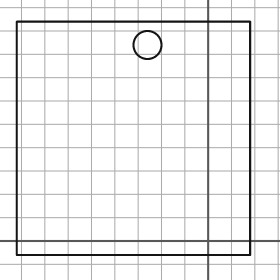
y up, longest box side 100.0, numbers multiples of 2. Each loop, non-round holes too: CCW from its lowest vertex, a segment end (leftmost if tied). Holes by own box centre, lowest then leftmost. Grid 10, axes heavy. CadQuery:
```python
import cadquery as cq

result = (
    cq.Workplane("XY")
    .moveTo(-82.0, -6.0)
    .lineTo(18.0, -6.0)
    .lineTo(18.0, 94.0)
    .lineTo(-82.0, 94.0)
    .close()
    .moveTo(-26.0, 84.0)
    .circle(6.0)
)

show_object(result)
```